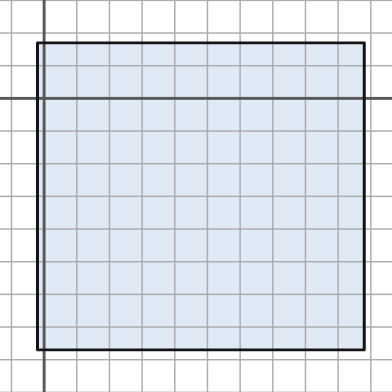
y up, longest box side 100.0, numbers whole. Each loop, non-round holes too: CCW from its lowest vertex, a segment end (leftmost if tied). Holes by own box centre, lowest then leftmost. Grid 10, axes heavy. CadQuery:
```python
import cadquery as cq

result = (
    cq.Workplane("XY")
    .moveTo(-2.0, -77.0)
    .lineTo(98.0, -77.0)
    .lineTo(98.0, 17.0)
    .lineTo(-2.0, 17.0)
    .close()
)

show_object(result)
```